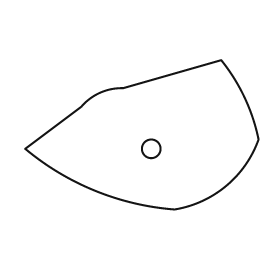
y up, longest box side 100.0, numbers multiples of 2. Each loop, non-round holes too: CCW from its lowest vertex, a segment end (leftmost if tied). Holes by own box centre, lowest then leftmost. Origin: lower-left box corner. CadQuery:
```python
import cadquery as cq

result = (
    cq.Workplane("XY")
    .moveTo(64.0, 0.0)
    .threePointArc((86.0, 10.0), (100.0, 30.0))
    .threePointArc((94.0, 48.0), (84.0, 64.0))
    .lineTo(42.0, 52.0)
    .threePointArc((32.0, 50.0), (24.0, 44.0))
    .lineTo(0.0, 26.0)
    .threePointArc((30.0, 8.0), (64.0, 0.0))
    .close()
    .moveTo(54.0, 26.0)
    .circle(4.0)
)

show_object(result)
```